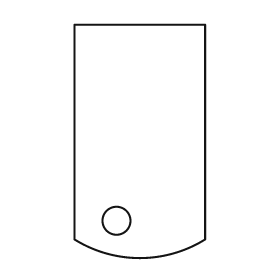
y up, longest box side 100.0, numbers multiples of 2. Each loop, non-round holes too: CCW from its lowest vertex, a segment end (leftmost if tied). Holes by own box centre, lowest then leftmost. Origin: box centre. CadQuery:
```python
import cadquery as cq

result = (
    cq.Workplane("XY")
    .moveTo(-28.0, -42.0)
    .threePointArc((0.0, -50.0), (28.0, -42.0))
    .lineTo(28.0, 50.0)
    .lineTo(-28.0, 50.0)
    .close()
    .moveTo(-10.0, -34.0)
    .circle(6.0)
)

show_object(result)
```